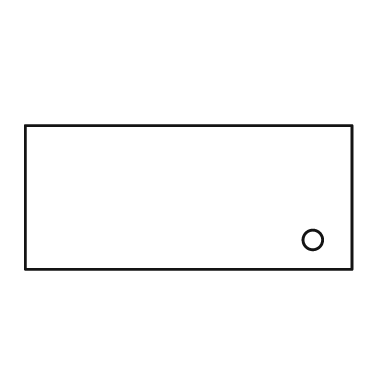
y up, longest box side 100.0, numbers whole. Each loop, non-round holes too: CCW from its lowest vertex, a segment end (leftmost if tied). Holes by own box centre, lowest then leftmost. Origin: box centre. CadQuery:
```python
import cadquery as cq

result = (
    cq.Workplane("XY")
    .moveTo(-50.0, -22.0)
    .lineTo(50.0, -22.0)
    .lineTo(50.0, 22.0)
    .lineTo(-50.0, 22.0)
    .close()
    .moveTo(38.0, -13.0)
    .circle(3.0)
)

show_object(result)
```